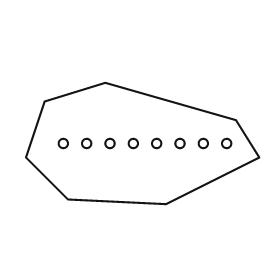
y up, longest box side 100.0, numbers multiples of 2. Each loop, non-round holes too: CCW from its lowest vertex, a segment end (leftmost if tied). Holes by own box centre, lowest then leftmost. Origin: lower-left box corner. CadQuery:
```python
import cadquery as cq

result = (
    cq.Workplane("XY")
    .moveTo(60.0, 0.0)
    .lineTo(100.0, 20.0)
    .lineTo(90.0, 36.0)
    .lineTo(34.0, 52.0)
    .lineTo(8.0, 44.0)
    .lineTo(0.0, 20.0)
    .lineTo(18.0, 2.0)
    .close()
    .moveTo(16.0, 26.0)
    .circle(2.0)
    .moveTo(26.0, 26.0)
    .circle(2.0)
    .moveTo(36.0, 26.0)
    .circle(2.0)
    .moveTo(46.0, 26.0)
    .circle(2.0)
    .moveTo(56.0, 26.0)
    .circle(2.0)
    .moveTo(66.0, 26.0)
    .circle(2.0)
    .moveTo(76.0, 26.0)
    .circle(2.0)
    .moveTo(86.0, 26.0)
    .circle(2.0)
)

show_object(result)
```